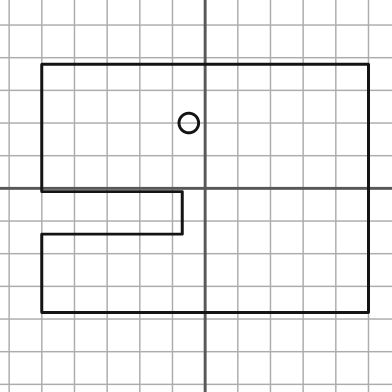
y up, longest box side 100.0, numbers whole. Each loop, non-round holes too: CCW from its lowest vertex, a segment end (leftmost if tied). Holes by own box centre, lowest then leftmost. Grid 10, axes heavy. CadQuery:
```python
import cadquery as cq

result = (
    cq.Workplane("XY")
    .moveTo(-50.0, -38.0)
    .lineTo(50.0, -38.0)
    .lineTo(50.0, 38.0)
    .lineTo(-50.0, 38.0)
    .lineTo(-50.0, -1.0)
    .lineTo(-7.0, -1.0)
    .lineTo(-7.0, -14.0)
    .lineTo(-50.0, -14.0)
    .close()
    .moveTo(-5.0, 20.0)
    .circle(3.0)
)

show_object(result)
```